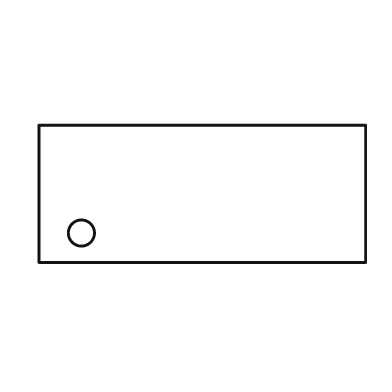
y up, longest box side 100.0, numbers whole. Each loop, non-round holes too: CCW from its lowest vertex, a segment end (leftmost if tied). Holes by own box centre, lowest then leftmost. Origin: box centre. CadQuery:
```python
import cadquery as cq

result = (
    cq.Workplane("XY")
    .moveTo(-50.0, -21.0)
    .lineTo(50.0, -21.0)
    .lineTo(50.0, 21.0)
    .lineTo(-50.0, 21.0)
    .close()
    .moveTo(-37.0, -12.0)
    .circle(4.0)
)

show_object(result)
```